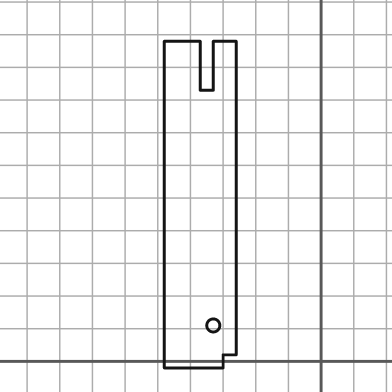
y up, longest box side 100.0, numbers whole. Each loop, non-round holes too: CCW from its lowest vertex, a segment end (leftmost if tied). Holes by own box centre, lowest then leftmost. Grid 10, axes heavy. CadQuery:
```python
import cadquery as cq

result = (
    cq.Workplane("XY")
    .moveTo(-48.0, -2.0)
    .lineTo(-30.0, -2.0)
    .lineTo(-30.0, 2.0)
    .lineTo(-26.0, 2.0)
    .lineTo(-26.0, 98.0)
    .lineTo(-33.0, 98.0)
    .lineTo(-33.0, 83.0)
    .lineTo(-37.0, 83.0)
    .lineTo(-37.0, 98.0)
    .lineTo(-48.0, 98.0)
    .close()
    .moveTo(-33.0, 11.0)
    .circle(2.0)
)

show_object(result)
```